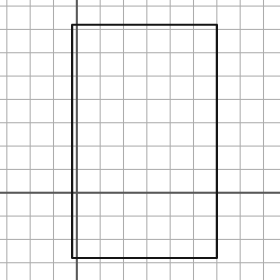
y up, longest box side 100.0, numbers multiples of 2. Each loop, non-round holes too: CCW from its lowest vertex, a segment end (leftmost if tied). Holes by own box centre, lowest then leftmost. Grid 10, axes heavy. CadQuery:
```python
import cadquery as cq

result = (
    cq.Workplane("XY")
    .moveTo(-2.0, -28.0)
    .lineTo(60.0, -28.0)
    .lineTo(60.0, 72.0)
    .lineTo(-2.0, 72.0)
    .close()
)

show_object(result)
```